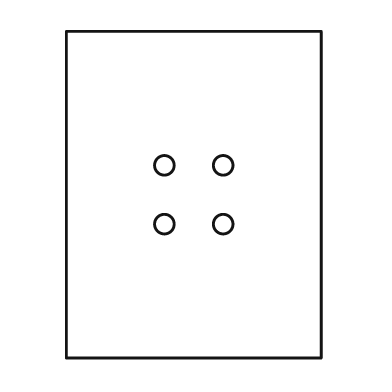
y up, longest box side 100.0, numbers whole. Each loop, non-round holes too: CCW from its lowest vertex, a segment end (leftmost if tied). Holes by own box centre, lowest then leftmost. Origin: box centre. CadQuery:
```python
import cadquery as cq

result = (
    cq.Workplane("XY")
    .moveTo(-39.0, -50.0)
    .lineTo(39.0, -50.0)
    .lineTo(39.0, 50.0)
    .lineTo(-39.0, 50.0)
    .close()
    .moveTo(-9.0, -9.0)
    .circle(3.0)
    .moveTo(9.0, -9.0)
    .circle(3.0)
    .moveTo(-9.0, 9.0)
    .circle(3.0)
    .moveTo(9.0, 9.0)
    .circle(3.0)
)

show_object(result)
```